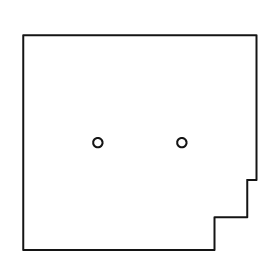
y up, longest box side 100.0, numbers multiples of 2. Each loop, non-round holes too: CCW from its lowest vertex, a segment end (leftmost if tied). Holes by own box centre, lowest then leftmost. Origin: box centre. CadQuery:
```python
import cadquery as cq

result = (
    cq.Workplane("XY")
    .moveTo(-50.0, -46.0)
    .lineTo(32.0, -46.0)
    .lineTo(32.0, -32.0)
    .lineTo(46.0, -32.0)
    .lineTo(46.0, -16.0)
    .lineTo(50.0, -16.0)
    .lineTo(50.0, 46.0)
    .lineTo(-50.0, 46.0)
    .close()
    .moveTo(-18.0, 0.0)
    .circle(2.0)
    .moveTo(18.0, 0.0)
    .circle(2.0)
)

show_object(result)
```